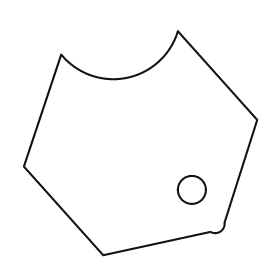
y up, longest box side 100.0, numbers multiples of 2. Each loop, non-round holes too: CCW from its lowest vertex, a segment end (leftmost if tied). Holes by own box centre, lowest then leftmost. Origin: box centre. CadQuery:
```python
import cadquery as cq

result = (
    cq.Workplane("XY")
    .moveTo(-16.0, -48.0)
    .lineTo(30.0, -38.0)
    .threePointArc((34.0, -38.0), (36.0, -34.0))
    .lineTo(50.0, 10.0)
    .lineTo(16.0, 48.0)
    .threePointArc((-6.0, 28.0), (-34.0, 38.0))
    .lineTo(-50.0, -10.0)
    .close()
    .moveTo(22.0, -20.0)
    .circle(6.0)
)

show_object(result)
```